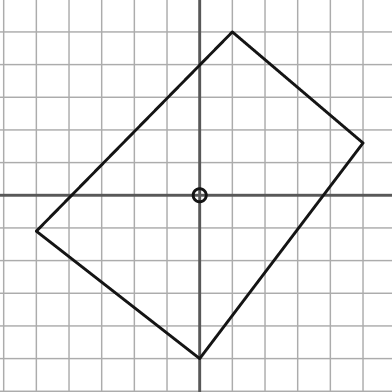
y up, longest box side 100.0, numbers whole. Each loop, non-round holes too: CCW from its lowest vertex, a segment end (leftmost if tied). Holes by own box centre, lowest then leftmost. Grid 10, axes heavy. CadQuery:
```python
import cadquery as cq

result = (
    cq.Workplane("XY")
    .moveTo(0.0, -50.0)
    .lineTo(50.0, 16.0)
    .lineTo(10.0, 50.0)
    .lineTo(-50.0, -11.0)
    .close()
    .moveTo(0.0, 0.0)
    .circle(2.0)
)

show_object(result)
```